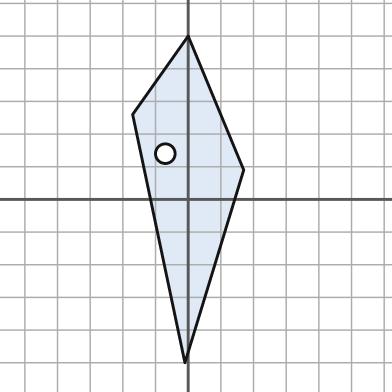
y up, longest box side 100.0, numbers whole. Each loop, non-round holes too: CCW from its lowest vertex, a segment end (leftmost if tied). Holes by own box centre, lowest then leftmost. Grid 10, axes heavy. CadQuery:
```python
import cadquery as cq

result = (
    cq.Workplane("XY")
    .moveTo(-1.0, -50.0)
    .lineTo(17.0, 9.0)
    .lineTo(0.0, 50.0)
    .lineTo(-17.0, 26.0)
    .close()
    .moveTo(-7.0, 14.0)
    .circle(3.0)
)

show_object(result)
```